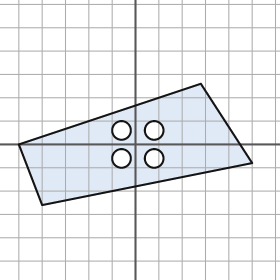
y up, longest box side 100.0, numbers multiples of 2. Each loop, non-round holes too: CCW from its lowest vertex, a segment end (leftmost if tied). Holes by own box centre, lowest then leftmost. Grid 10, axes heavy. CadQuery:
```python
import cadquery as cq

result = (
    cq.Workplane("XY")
    .moveTo(-40.0, -26.0)
    .lineTo(50.0, -8.0)
    .lineTo(28.0, 26.0)
    .lineTo(-50.0, 0.0)
    .close()
    .moveTo(-6.0, -6.0)
    .circle(4.0)
    .moveTo(8.0, -6.0)
    .circle(4.0)
    .moveTo(-6.0, 6.0)
    .circle(4.0)
    .moveTo(8.0, 6.0)
    .circle(4.0)
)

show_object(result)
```